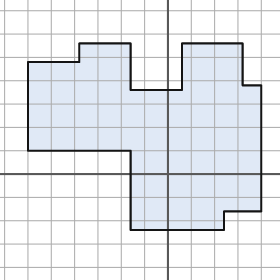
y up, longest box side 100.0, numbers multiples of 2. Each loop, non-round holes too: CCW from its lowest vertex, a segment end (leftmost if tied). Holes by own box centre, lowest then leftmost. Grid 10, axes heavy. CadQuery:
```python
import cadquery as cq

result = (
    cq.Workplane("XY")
    .moveTo(-16.0, -24.0)
    .lineTo(24.0, -24.0)
    .lineTo(24.0, -16.0)
    .lineTo(40.0, -16.0)
    .lineTo(40.0, 38.0)
    .lineTo(32.0, 38.0)
    .lineTo(32.0, 56.0)
    .lineTo(6.0, 56.0)
    .lineTo(6.0, 36.0)
    .lineTo(-16.0, 36.0)
    .lineTo(-16.0, 56.0)
    .lineTo(-38.0, 56.0)
    .lineTo(-38.0, 48.0)
    .lineTo(-60.0, 48.0)
    .lineTo(-60.0, 10.0)
    .lineTo(-16.0, 10.0)
    .close()
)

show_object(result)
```